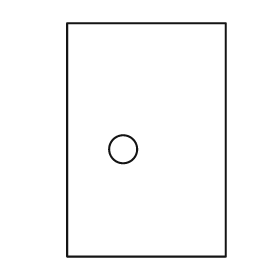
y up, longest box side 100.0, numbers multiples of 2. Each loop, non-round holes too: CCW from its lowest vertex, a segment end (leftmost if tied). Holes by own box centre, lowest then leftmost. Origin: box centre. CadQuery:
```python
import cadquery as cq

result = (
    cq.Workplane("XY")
    .moveTo(-34.0, -50.0)
    .lineTo(34.0, -50.0)
    .lineTo(34.0, 50.0)
    .lineTo(-34.0, 50.0)
    .close()
    .moveTo(-10.0, -4.0)
    .circle(6.0)
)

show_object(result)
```